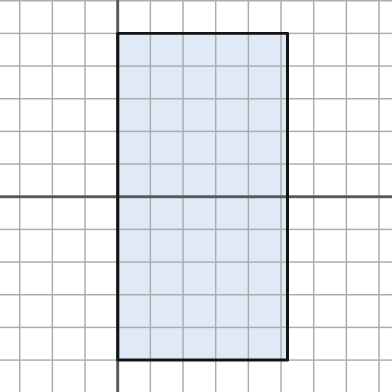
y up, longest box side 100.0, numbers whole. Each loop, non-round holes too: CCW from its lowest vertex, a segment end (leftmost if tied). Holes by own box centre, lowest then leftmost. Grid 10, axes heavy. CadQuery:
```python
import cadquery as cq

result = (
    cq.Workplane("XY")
    .moveTo(0.0, -50.0)
    .lineTo(52.0, -50.0)
    .lineTo(52.0, 50.0)
    .lineTo(0.0, 50.0)
    .close()
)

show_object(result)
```